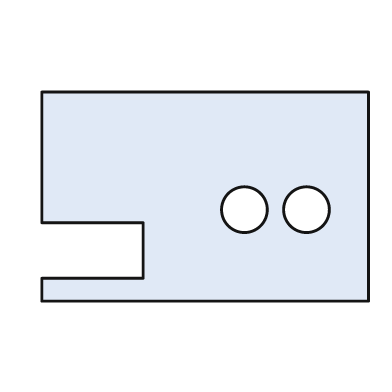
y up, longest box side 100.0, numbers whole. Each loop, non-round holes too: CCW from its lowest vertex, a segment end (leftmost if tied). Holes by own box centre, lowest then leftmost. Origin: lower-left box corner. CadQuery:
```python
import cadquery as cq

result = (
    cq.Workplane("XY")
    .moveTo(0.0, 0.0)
    .lineTo(100.0, 0.0)
    .lineTo(100.0, 64.0)
    .lineTo(0.0, 64.0)
    .lineTo(0.0, 24.0)
    .lineTo(31.0, 24.0)
    .lineTo(31.0, 7.0)
    .lineTo(0.0, 7.0)
    .close()
    .moveTo(62.0, 28.0)
    .circle(7.0)
    .moveTo(81.0, 28.0)
    .circle(7.0)
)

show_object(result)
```